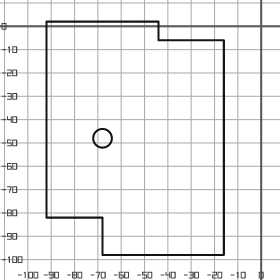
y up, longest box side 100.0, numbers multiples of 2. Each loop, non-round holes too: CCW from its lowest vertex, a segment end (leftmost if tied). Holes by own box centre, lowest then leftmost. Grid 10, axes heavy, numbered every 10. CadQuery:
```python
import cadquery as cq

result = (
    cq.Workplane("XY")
    .moveTo(-68.0, -98.0)
    .lineTo(-16.0, -98.0)
    .lineTo(-16.0, -6.0)
    .lineTo(-44.0, -6.0)
    .lineTo(-44.0, 2.0)
    .lineTo(-92.0, 2.0)
    .lineTo(-92.0, -82.0)
    .lineTo(-68.0, -82.0)
    .close()
    .moveTo(-68.0, -48.0)
    .circle(4.0)
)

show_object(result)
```